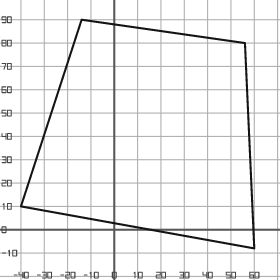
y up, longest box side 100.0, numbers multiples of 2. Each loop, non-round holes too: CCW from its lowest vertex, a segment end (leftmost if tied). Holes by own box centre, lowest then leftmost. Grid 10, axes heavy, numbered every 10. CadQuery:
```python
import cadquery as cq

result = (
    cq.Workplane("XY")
    .moveTo(60.0, -8.0)
    .lineTo(56.0, 80.0)
    .lineTo(-14.0, 90.0)
    .lineTo(-40.0, 10.0)
    .close()
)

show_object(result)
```